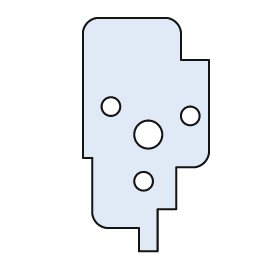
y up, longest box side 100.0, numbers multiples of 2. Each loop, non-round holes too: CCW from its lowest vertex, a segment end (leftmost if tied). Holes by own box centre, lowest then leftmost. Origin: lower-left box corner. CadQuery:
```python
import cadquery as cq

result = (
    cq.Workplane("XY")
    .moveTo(24.0, 0.0)
    .lineTo(32.0, 0.0)
    .lineTo(32.0, 18.0)
    .lineTo(40.0, 18.0)
    .lineTo(40.0, 36.0)
    .lineTo(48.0, 36.0)
    .threePointArc((52.0, 38.0), (54.0, 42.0))
    .lineTo(54.0, 82.0)
    .lineTo(42.0, 82.0)
    .lineTo(42.0, 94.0)
    .threePointArc((40.0, 98.0), (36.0, 100.0))
    .lineTo(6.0, 100.0)
    .threePointArc((2.0, 98.0), (0.0, 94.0))
    .lineTo(0.0, 40.0)
    .lineTo(4.0, 40.0)
    .lineTo(4.0, 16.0)
    .threePointArc((6.0, 12.0), (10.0, 10.0))
    .lineTo(24.0, 10.0)
    .close()
    .moveTo(26.0, 30.0)
    .circle(4.0)
    .moveTo(28.0, 50.0)
    .circle(6.0)
    .moveTo(46.0, 58.0)
    .circle(4.0)
    .moveTo(12.0, 62.0)
    .circle(4.0)
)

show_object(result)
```